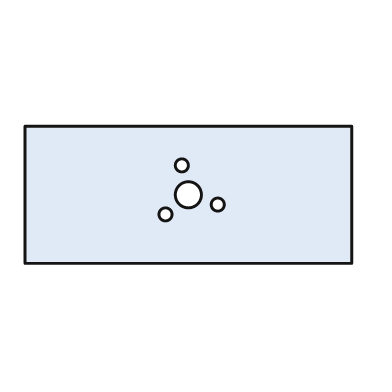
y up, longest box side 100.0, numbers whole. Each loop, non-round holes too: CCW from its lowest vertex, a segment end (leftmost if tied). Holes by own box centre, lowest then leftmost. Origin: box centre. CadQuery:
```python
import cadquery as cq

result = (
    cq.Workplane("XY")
    .moveTo(-50.0, -21.0)
    .lineTo(50.0, -21.0)
    .lineTo(50.0, 21.0)
    .lineTo(-50.0, 21.0)
    .close()
    .moveTo(-7.0, -6.0)
    .circle(2.0)
    .moveTo(9.0, -3.0)
    .circle(2.0)
    .moveTo(0.0, 0.0)
    .circle(4.0)
    .moveTo(-2.0, 9.0)
    .circle(2.0)
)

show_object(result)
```